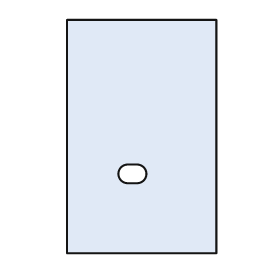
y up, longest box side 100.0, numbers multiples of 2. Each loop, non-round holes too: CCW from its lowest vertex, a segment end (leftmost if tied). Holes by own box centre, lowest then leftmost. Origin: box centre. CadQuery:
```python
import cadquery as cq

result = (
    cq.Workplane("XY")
    .moveTo(-32.0, -50.0)
    .lineTo(32.0, -50.0)
    .lineTo(32.0, 50.0)
    .lineTo(-32.0, 50.0)
    .close()
    .moveTo(-6.0, -20.0)
    .lineTo(-2.0, -20.0)
    .threePointArc((2.0, -16.0), (-2.0, -12.0))
    .lineTo(-6.0, -12.0)
    .threePointArc((-10.0, -16.0), (-6.0, -20.0))
    .close()
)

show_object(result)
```